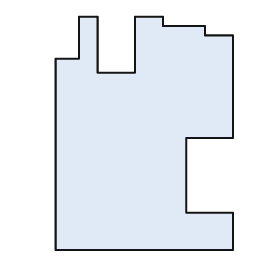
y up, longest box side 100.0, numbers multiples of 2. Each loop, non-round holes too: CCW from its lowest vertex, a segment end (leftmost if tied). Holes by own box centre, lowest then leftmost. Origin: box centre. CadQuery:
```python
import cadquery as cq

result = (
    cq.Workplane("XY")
    .moveTo(-38.0, -50.0)
    .lineTo(38.0, -50.0)
    .lineTo(38.0, -34.0)
    .lineTo(18.0, -34.0)
    .lineTo(18.0, -2.0)
    .lineTo(38.0, -2.0)
    .lineTo(38.0, 42.0)
    .lineTo(26.0, 42.0)
    .lineTo(26.0, 46.0)
    .lineTo(8.0, 46.0)
    .lineTo(8.0, 50.0)
    .lineTo(-4.0, 50.0)
    .lineTo(-4.0, 26.0)
    .lineTo(-20.0, 26.0)
    .lineTo(-20.0, 50.0)
    .lineTo(-28.0, 50.0)
    .lineTo(-28.0, 32.0)
    .lineTo(-38.0, 32.0)
    .close()
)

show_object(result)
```